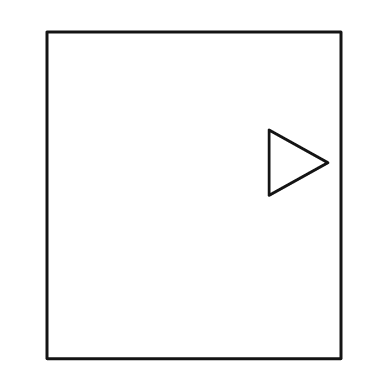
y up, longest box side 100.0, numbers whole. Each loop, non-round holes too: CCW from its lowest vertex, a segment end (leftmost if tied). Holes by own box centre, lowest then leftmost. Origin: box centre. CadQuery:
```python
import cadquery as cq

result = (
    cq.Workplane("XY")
    .moveTo(-45.0, -50.0)
    .lineTo(45.0, -50.0)
    .lineTo(45.0, 50.0)
    .lineTo(-45.0, 50.0)
    .close()
    .moveTo(23.0, 0.0)
    .lineTo(41.0, 10.0)
    .lineTo(23.0, 20.0)
    .close()
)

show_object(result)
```